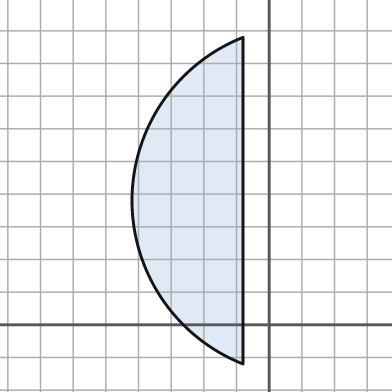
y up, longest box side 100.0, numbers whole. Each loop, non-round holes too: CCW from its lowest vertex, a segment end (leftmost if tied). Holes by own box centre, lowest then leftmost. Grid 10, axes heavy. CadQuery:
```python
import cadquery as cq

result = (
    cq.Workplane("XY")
    .moveTo(-8.0, -12.0)
    .lineTo(-8.0, 88.0)
    .threePointArc((-42.0, 38.0), (-8.0, -12.0))
    .close()
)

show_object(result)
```